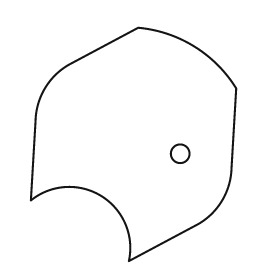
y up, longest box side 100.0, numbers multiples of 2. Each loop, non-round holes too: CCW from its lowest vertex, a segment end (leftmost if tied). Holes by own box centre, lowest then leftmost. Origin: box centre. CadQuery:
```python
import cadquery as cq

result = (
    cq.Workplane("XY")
    .moveTo(-2.0, -50.0)
    .lineTo(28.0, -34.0)
    .threePointArc((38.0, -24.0), (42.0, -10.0))
    .lineTo(44.0, 24.0)
    .threePointArc((26.0, 42.0), (2.0, 50.0))
    .lineTo(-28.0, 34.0)
    .threePointArc((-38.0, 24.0), (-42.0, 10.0))
    .lineTo(-44.0, -24.0)
    .threePointArc((-14.0, -22.0), (-2.0, -50.0))
    .close()
    .moveTo(20.0, -4.0)
    .circle(4.0)
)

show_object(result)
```